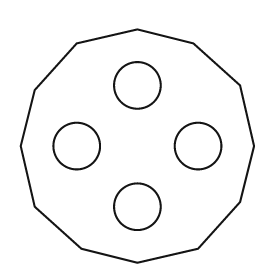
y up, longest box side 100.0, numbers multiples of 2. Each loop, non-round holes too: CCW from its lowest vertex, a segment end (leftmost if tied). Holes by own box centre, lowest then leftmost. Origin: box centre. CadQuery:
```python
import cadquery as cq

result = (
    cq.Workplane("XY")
    .moveTo(0.0, -50.0)
    .lineTo(26.0, -44.0)
    .lineTo(44.0, -24.0)
    .lineTo(50.0, 0.0)
    .lineTo(44.0, 26.0)
    .lineTo(24.0, 44.0)
    .lineTo(0.0, 50.0)
    .lineTo(-26.0, 44.0)
    .lineTo(-44.0, 24.0)
    .lineTo(-50.0, 0.0)
    .lineTo(-44.0, -26.0)
    .lineTo(-24.0, -44.0)
    .close()
    .moveTo(0.0, -26.0)
    .circle(10.0)
    .moveTo(-26.0, 0.0)
    .circle(10.0)
    .moveTo(26.0, 0.0)
    .circle(10.0)
    .moveTo(0.0, 26.0)
    .circle(10.0)
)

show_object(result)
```